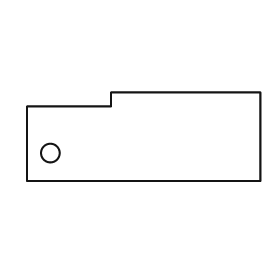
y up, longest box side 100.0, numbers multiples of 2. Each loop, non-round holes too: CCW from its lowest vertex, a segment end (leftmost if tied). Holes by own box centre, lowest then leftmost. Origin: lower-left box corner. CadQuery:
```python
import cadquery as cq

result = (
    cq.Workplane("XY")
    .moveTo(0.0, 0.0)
    .lineTo(100.0, 0.0)
    .lineTo(100.0, 38.0)
    .lineTo(36.0, 38.0)
    .lineTo(36.0, 32.0)
    .lineTo(0.0, 32.0)
    .close()
    .moveTo(10.0, 12.0)
    .circle(4.0)
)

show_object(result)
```